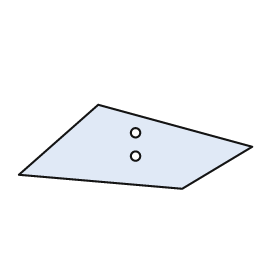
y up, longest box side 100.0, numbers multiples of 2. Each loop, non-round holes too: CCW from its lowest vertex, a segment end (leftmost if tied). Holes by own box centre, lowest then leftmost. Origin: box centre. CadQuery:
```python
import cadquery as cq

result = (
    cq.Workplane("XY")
    .moveTo(20.0, -18.0)
    .lineTo(50.0, 0.0)
    .lineTo(-16.0, 18.0)
    .lineTo(-50.0, -12.0)
    .close()
    .moveTo(0.0, -4.0)
    .circle(2.0)
    .moveTo(0.0, 6.0)
    .circle(2.0)
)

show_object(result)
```